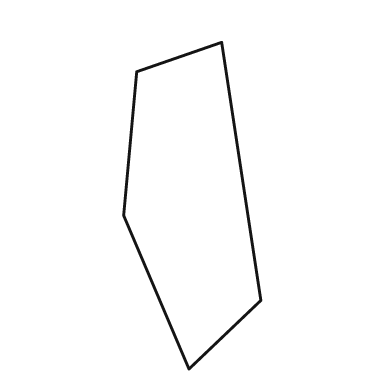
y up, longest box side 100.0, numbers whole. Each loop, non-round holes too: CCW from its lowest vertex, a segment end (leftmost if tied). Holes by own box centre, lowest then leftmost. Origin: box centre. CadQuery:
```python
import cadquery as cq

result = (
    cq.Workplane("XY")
    .moveTo(-1.0, -50.0)
    .lineTo(21.0, -29.0)
    .lineTo(9.0, 50.0)
    .lineTo(-17.0, 41.0)
    .lineTo(-21.0, -3.0)
    .close()
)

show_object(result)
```